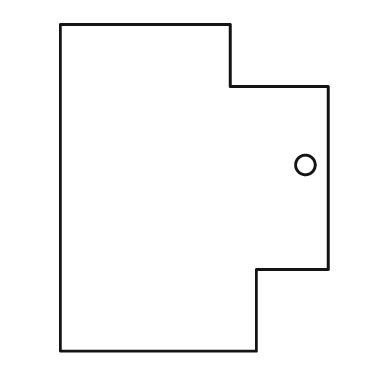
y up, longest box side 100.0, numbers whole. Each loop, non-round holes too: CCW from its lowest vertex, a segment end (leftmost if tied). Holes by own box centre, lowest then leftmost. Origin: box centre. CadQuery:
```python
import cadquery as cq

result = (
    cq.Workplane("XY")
    .moveTo(-41.0, -50.0)
    .lineTo(19.0, -50.0)
    .lineTo(19.0, -25.0)
    .lineTo(41.0, -25.0)
    .lineTo(41.0, 31.0)
    .lineTo(11.0, 31.0)
    .lineTo(11.0, 50.0)
    .lineTo(-41.0, 50.0)
    .close()
    .moveTo(34.0, 7.0)
    .circle(3.0)
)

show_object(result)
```